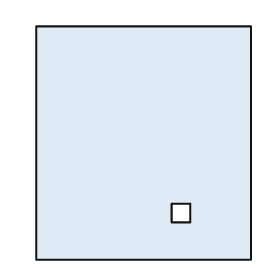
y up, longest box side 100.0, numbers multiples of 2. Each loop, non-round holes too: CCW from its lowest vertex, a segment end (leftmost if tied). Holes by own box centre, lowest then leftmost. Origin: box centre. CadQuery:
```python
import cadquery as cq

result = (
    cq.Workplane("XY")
    .moveTo(-46.0, -50.0)
    .lineTo(46.0, -50.0)
    .lineTo(46.0, 50.0)
    .lineTo(-46.0, 50.0)
    .close()
    .moveTo(12.0, -34.0)
    .lineTo(20.0, -34.0)
    .lineTo(20.0, -26.0)
    .lineTo(12.0, -26.0)
    .close()
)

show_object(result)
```